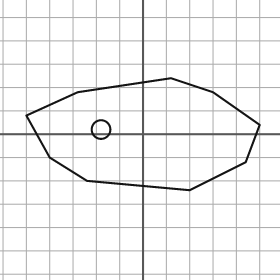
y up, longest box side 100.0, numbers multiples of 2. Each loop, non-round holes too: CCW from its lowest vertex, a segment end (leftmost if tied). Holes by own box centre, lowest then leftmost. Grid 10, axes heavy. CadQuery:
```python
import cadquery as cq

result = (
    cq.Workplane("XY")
    .moveTo(20.0, -24.0)
    .lineTo(44.0, -12.0)
    .lineTo(50.0, 4.0)
    .lineTo(30.0, 18.0)
    .lineTo(12.0, 24.0)
    .lineTo(-28.0, 18.0)
    .lineTo(-50.0, 8.0)
    .lineTo(-40.0, -10.0)
    .lineTo(-24.0, -20.0)
    .close()
    .moveTo(-18.0, 2.0)
    .circle(4.0)
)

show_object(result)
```